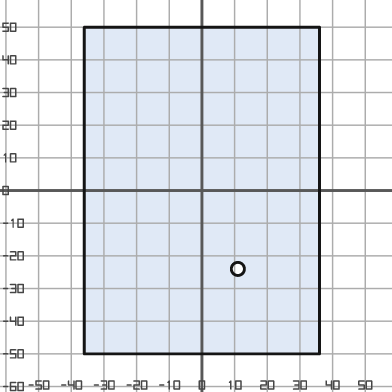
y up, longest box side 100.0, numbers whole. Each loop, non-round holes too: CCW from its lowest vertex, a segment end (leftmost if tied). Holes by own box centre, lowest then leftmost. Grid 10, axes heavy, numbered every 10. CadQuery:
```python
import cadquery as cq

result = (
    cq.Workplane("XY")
    .moveTo(-36.0, -50.0)
    .lineTo(36.0, -50.0)
    .lineTo(36.0, 50.0)
    .lineTo(-36.0, 50.0)
    .close()
    .moveTo(11.0, -24.0)
    .circle(2.0)
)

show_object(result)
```